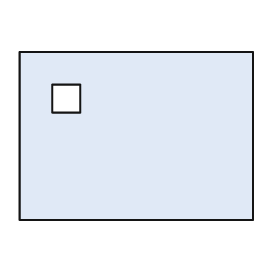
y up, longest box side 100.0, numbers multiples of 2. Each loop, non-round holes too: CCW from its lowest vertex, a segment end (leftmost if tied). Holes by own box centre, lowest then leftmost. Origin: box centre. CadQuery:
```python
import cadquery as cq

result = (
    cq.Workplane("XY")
    .moveTo(-50.0, -36.0)
    .lineTo(50.0, -36.0)
    .lineTo(50.0, 36.0)
    .lineTo(-50.0, 36.0)
    .close()
    .moveTo(-36.0, 10.0)
    .lineTo(-24.0, 10.0)
    .lineTo(-24.0, 22.0)
    .lineTo(-36.0, 22.0)
    .close()
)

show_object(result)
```